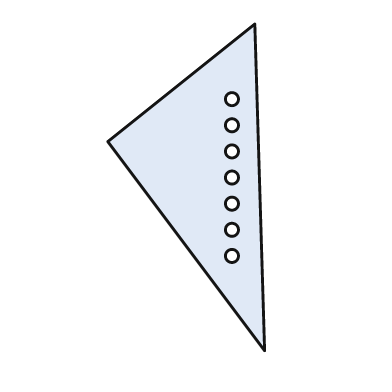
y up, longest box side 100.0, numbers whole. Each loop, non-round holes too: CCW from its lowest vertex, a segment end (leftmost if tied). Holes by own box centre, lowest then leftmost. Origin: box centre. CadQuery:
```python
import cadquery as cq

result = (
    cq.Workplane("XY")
    .moveTo(24.0, -50.0)
    .lineTo(21.0, 50.0)
    .lineTo(-24.0, 14.0)
    .close()
    .moveTo(14.0, -21.0)
    .circle(2.0)
    .moveTo(14.0, -13.0)
    .circle(2.0)
    .moveTo(14.0, -5.0)
    .circle(2.0)
    .moveTo(14.0, 3.0)
    .circle(2.0)
    .moveTo(14.0, 11.0)
    .circle(2.0)
    .moveTo(14.0, 19.0)
    .circle(2.0)
    .moveTo(14.0, 27.0)
    .circle(2.0)
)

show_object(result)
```